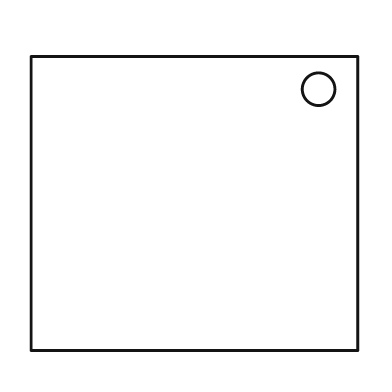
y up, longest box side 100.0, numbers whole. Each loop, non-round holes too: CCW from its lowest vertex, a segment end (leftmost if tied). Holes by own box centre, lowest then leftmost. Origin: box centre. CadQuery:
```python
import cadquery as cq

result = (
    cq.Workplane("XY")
    .moveTo(-50.0, -45.0)
    .lineTo(50.0, -45.0)
    .lineTo(50.0, 45.0)
    .lineTo(-50.0, 45.0)
    .close()
    .moveTo(38.0, 35.0)
    .circle(5.0)
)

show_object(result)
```